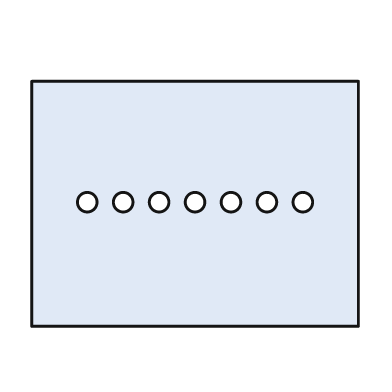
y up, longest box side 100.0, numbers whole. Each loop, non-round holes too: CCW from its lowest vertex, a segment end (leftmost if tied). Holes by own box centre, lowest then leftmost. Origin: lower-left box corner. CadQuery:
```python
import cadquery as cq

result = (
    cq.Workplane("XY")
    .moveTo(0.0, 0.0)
    .lineTo(100.0, 0.0)
    .lineTo(100.0, 75.0)
    .lineTo(0.0, 75.0)
    .close()
    .moveTo(17.0, 38.0)
    .circle(3.0)
    .moveTo(28.0, 38.0)
    .circle(3.0)
    .moveTo(39.0, 38.0)
    .circle(3.0)
    .moveTo(50.0, 38.0)
    .circle(3.0)
    .moveTo(61.0, 38.0)
    .circle(3.0)
    .moveTo(72.0, 38.0)
    .circle(3.0)
    .moveTo(83.0, 38.0)
    .circle(3.0)
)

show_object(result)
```